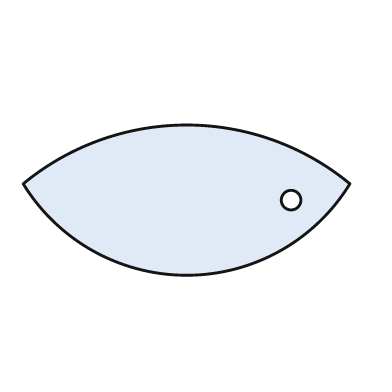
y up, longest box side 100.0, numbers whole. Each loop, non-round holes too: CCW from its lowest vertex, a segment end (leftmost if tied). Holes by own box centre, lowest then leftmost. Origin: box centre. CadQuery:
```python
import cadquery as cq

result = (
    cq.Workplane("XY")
    .moveTo(-50.0, 5.0)
    .threePointArc((0.0, -23.0), (50.0, 5.0))
    .threePointArc((0.0, 23.0), (-50.0, 5.0))
    .close()
    .moveTo(32.0, 0.0)
    .circle(3.0)
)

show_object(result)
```